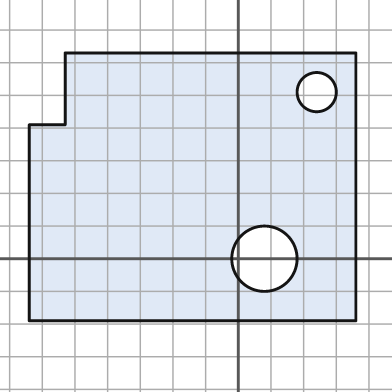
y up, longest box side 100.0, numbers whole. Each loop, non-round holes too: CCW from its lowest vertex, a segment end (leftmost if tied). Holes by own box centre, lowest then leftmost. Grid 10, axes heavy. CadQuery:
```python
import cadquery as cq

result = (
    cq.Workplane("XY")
    .moveTo(-64.0, -19.0)
    .lineTo(36.0, -19.0)
    .lineTo(36.0, 63.0)
    .lineTo(-53.0, 63.0)
    .lineTo(-53.0, 41.0)
    .lineTo(-64.0, 41.0)
    .close()
    .moveTo(8.0, 0.0)
    .circle(10.0)
    .moveTo(24.0, 51.0)
    .circle(6.0)
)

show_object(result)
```